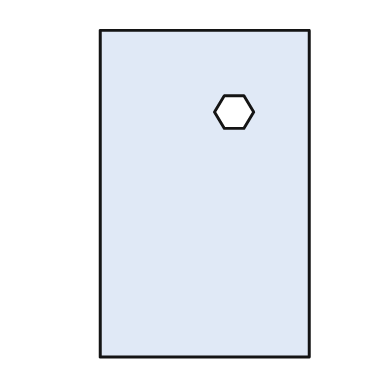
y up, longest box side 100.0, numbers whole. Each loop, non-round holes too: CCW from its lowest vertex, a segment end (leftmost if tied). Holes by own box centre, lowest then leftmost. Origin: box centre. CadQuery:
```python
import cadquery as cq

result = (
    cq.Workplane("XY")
    .moveTo(-32.0, -50.0)
    .lineTo(32.0, -50.0)
    .lineTo(32.0, 50.0)
    .lineTo(-32.0, 50.0)
    .close()
    .moveTo(6.0, 20.0)
    .lineTo(12.0, 20.0)
    .lineTo(15.0, 25.0)
    .lineTo(12.0, 30.0)
    .lineTo(6.0, 30.0)
    .lineTo(3.0, 25.0)
    .close()
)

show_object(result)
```